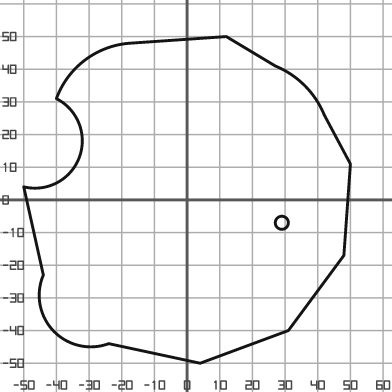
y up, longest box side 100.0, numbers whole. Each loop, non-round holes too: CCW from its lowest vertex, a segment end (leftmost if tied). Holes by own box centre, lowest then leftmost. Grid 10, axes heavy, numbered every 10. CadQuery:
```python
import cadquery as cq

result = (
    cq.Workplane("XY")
    .moveTo(4.0, -50.0)
    .lineTo(31.0, -40.0)
    .lineTo(48.0, -17.0)
    .lineTo(50.0, 11.0)
    .lineTo(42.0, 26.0)
    .threePointArc((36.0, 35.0), (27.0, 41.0))
    .lineTo(12.0, 50.0)
    .lineTo(-17.0, 48.0)
    .threePointArc((-31.0, 43.0), (-40.0, 31.0))
    .threePointArc((-33.0, 13.0), (-50.0, 4.0))
    .lineTo(-44.0, -23.0)
    .threePointArc((-41.0, -40.0), (-24.0, -44.0))
    .close()
    .moveTo(29.0, -7.0)
    .circle(2.0)
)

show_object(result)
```